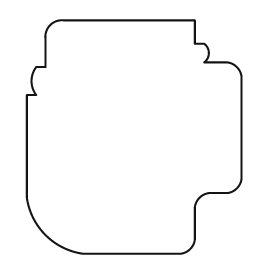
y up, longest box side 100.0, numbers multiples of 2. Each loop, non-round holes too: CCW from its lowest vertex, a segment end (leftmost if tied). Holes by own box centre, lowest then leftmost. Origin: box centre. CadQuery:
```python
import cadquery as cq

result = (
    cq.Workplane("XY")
    .moveTo(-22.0, -50.0)
    .lineTo(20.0, -50.0)
    .threePointArc((24.0, -48.0), (26.0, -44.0))
    .lineTo(26.0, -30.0)
    .threePointArc((28.0, -26.0), (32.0, -24.0))
    .lineTo(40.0, -24.0)
    .threePointArc((44.0, -22.0), (46.0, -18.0))
    .lineTo(46.0, 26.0)
    .threePointArc((44.0, 30.0), (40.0, 32.0))
    .lineTo(30.0, 32.0)
    .threePointArc((32.0, 36.0), (30.0, 40.0))
    .lineTo(26.0, 40.0)
    .lineTo(26.0, 50.0)
    .lineTo(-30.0, 50.0)
    .threePointArc((-36.0, 48.0), (-38.0, 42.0))
    .lineTo(-38.0, 30.0)
    .lineTo(-42.0, 30.0)
    .threePointArc((-44.0, 24.0), (-42.0, 18.0))
    .lineTo(-46.0, 18.0)
    .lineTo(-46.0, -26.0)
    .threePointArc((-38.0, -42.0), (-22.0, -50.0))
    .close()
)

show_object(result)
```